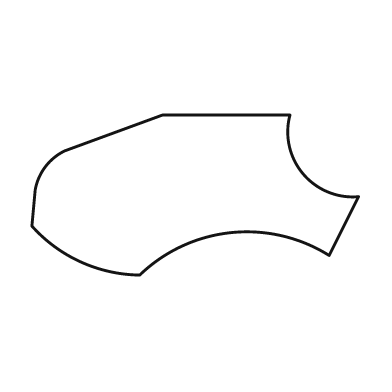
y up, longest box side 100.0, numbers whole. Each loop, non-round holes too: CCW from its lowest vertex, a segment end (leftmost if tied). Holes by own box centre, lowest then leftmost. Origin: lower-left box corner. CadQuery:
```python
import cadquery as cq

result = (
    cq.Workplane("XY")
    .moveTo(33.0, 0.0)
    .threePointArc((61.0, 13.0), (91.0, 6.0))
    .lineTo(100.0, 24.0)
    .threePointArc((83.0, 31.0), (79.0, 49.0))
    .lineTo(40.0, 49.0)
    .lineTo(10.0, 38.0)
    .threePointArc((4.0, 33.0), (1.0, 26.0))
    .lineTo(0.0, 15.0)
    .threePointArc((15.0, 4.0), (33.0, 0.0))
    .close()
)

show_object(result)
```